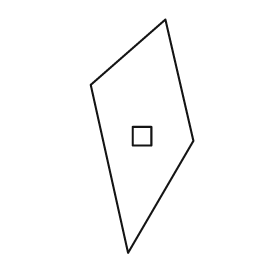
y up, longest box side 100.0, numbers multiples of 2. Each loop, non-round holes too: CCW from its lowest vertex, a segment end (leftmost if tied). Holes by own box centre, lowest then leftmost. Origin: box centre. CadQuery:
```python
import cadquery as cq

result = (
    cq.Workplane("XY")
    .moveTo(-6.0, -50.0)
    .lineTo(22.0, -2.0)
    .lineTo(10.0, 50.0)
    .lineTo(-22.0, 22.0)
    .close()
    .moveTo(-4.0, -4.0)
    .lineTo(4.0, -4.0)
    .lineTo(4.0, 4.0)
    .lineTo(-4.0, 4.0)
    .close()
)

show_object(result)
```